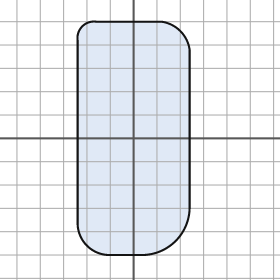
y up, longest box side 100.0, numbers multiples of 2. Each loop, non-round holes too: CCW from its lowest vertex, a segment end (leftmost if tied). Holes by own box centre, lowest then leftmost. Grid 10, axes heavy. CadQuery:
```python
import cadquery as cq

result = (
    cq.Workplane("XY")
    .moveTo(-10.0, -50.0)
    .lineTo(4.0, -50.0)
    .threePointArc((18.0, -44.0), (24.0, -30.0))
    .lineTo(24.0, 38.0)
    .threePointArc((20.0, 46.0), (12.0, 50.0))
    .lineTo(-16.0, 50.0)
    .threePointArc((-22.0, 48.0), (-24.0, 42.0))
    .lineTo(-24.0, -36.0)
    .threePointArc((-20.0, -46.0), (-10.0, -50.0))
    .close()
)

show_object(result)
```